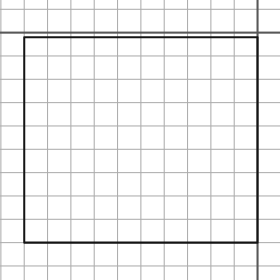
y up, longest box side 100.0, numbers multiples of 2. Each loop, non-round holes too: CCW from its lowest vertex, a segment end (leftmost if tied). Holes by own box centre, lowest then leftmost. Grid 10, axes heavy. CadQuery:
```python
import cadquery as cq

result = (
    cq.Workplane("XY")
    .moveTo(-100.0, -90.0)
    .lineTo(0.0, -90.0)
    .lineTo(0.0, -2.0)
    .lineTo(-100.0, -2.0)
    .close()
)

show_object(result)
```